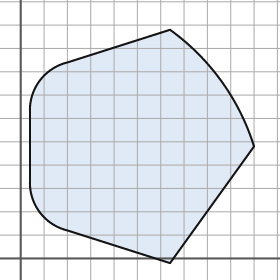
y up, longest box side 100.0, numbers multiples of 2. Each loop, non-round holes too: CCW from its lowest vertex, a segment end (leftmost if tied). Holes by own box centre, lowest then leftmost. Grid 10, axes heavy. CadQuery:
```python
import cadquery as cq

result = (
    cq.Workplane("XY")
    .moveTo(64.0, -2.0)
    .lineTo(100.0, 48.0)
    .threePointArc((86.0, 76.0), (64.0, 98.0))
    .lineTo(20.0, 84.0)
    .threePointArc((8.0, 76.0), (4.0, 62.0))
    .lineTo(4.0, 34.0)
    .threePointArc((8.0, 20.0), (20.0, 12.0))
    .close()
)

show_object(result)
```